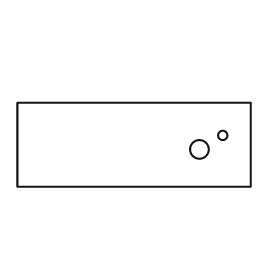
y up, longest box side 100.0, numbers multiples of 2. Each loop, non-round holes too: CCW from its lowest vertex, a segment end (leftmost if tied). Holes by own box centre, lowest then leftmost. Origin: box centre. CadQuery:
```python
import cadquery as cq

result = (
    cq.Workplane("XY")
    .moveTo(-50.0, -18.0)
    .lineTo(50.0, -18.0)
    .lineTo(50.0, 18.0)
    .lineTo(-50.0, 18.0)
    .close()
    .moveTo(28.0, -2.0)
    .circle(4.0)
    .moveTo(38.0, 4.0)
    .circle(2.0)
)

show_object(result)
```